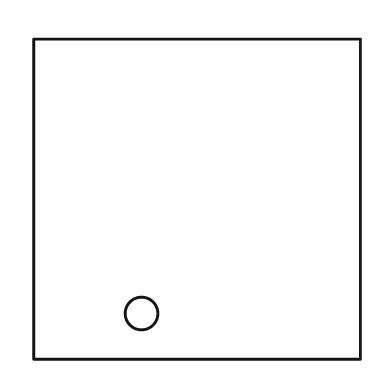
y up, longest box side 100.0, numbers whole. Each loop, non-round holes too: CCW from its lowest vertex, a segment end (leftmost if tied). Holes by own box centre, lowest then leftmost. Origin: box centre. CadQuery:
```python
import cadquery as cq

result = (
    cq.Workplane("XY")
    .moveTo(-50.0, -49.0)
    .lineTo(50.0, -49.0)
    .lineTo(50.0, 49.0)
    .lineTo(-50.0, 49.0)
    .close()
    .moveTo(-17.0, -35.0)
    .circle(5.0)
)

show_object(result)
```